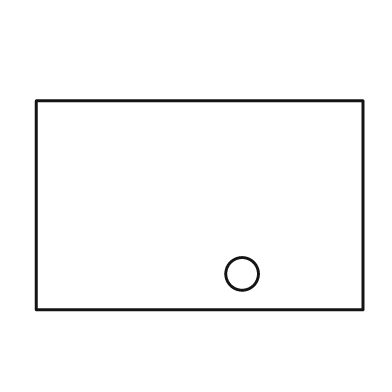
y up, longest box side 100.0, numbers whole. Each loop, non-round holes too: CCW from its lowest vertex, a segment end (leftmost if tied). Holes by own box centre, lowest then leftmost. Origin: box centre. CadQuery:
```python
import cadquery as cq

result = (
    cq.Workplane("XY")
    .moveTo(-50.0, -32.0)
    .lineTo(50.0, -32.0)
    .lineTo(50.0, 32.0)
    .lineTo(-50.0, 32.0)
    .close()
    .moveTo(13.0, -21.0)
    .circle(5.0)
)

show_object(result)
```